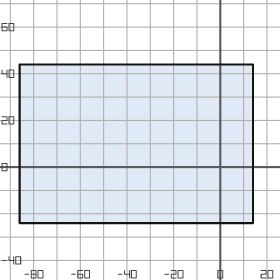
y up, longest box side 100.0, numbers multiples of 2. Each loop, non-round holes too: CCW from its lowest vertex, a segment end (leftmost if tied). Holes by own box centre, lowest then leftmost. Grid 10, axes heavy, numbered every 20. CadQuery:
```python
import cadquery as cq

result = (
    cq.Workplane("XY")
    .moveTo(-86.0, -24.0)
    .lineTo(14.0, -24.0)
    .lineTo(14.0, 44.0)
    .lineTo(-86.0, 44.0)
    .close()
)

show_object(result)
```